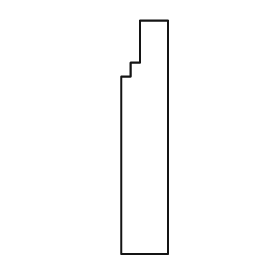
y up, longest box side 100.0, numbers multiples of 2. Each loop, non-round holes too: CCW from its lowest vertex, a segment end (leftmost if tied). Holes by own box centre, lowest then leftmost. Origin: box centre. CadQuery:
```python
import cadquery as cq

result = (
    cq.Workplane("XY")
    .moveTo(-10.0, -50.0)
    .lineTo(10.0, -50.0)
    .lineTo(10.0, 50.0)
    .lineTo(-2.0, 50.0)
    .lineTo(-2.0, 32.0)
    .lineTo(-6.0, 32.0)
    .lineTo(-6.0, 26.0)
    .lineTo(-10.0, 26.0)
    .close()
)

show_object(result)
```